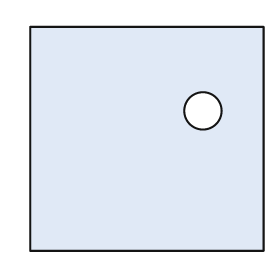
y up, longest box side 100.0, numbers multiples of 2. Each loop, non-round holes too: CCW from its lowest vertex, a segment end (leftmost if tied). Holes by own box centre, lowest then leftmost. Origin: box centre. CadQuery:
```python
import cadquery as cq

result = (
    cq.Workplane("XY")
    .moveTo(-50.0, -48.0)
    .lineTo(50.0, -48.0)
    .lineTo(50.0, 48.0)
    .lineTo(-50.0, 48.0)
    .close()
    .moveTo(24.0, 12.0)
    .circle(8.0)
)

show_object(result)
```